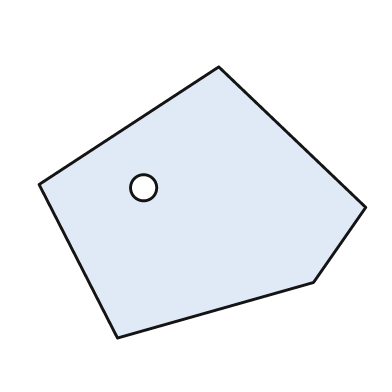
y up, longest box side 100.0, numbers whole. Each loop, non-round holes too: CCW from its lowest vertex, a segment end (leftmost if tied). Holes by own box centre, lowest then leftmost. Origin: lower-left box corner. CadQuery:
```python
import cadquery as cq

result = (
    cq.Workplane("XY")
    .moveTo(24.0, 0.0)
    .lineTo(84.0, 17.0)
    .lineTo(100.0, 40.0)
    .lineTo(55.0, 83.0)
    .lineTo(0.0, 47.0)
    .close()
    .moveTo(32.0, 46.0)
    .circle(4.0)
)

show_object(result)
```